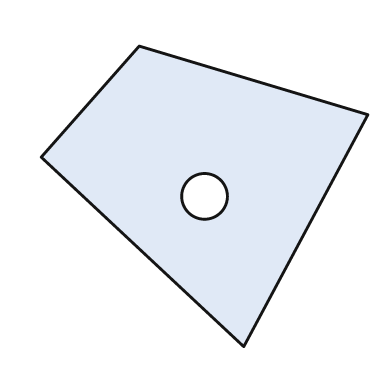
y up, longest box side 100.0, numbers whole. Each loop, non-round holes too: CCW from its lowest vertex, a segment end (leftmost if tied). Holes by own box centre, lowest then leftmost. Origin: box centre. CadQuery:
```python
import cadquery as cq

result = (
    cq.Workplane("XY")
    .moveTo(12.0, -46.0)
    .lineTo(50.0, 25.0)
    .lineTo(-20.0, 46.0)
    .lineTo(-50.0, 12.0)
    .close()
    .moveTo(0.0, 0.0)
    .circle(7.0)
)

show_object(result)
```